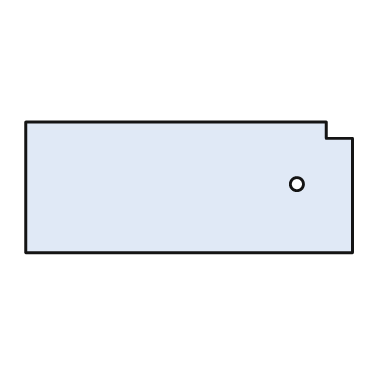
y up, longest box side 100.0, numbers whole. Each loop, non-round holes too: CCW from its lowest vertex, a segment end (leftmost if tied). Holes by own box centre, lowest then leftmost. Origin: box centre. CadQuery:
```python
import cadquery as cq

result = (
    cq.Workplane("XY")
    .moveTo(-50.0, -20.0)
    .lineTo(50.0, -20.0)
    .lineTo(50.0, 15.0)
    .lineTo(42.0, 15.0)
    .lineTo(42.0, 20.0)
    .lineTo(-50.0, 20.0)
    .close()
    .moveTo(33.0, 1.0)
    .circle(2.0)
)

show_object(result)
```